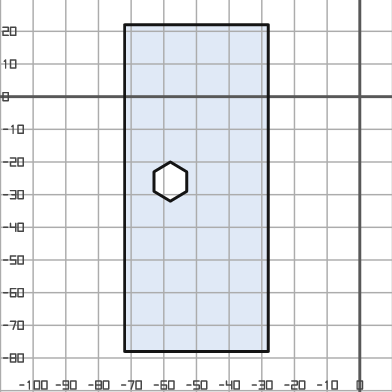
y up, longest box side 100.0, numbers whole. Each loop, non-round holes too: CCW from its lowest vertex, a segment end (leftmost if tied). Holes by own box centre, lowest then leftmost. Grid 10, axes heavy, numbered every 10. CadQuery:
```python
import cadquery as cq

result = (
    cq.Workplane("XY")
    .moveTo(-72.0, -78.0)
    .lineTo(-28.0, -78.0)
    .lineTo(-28.0, 22.0)
    .lineTo(-72.0, 22.0)
    .close()
    .moveTo(-58.0, -32.0)
    .lineTo(-53.0, -29.0)
    .lineTo(-53.0, -23.0)
    .lineTo(-58.0, -20.0)
    .lineTo(-63.0, -23.0)
    .lineTo(-63.0, -29.0)
    .close()
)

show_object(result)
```